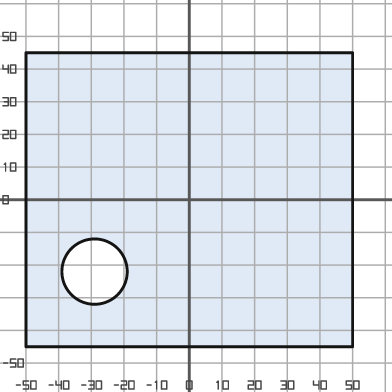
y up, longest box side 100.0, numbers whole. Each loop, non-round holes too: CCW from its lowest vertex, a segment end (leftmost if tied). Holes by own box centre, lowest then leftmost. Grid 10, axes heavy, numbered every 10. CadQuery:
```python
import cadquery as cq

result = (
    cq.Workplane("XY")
    .moveTo(-50.0, -45.0)
    .lineTo(50.0, -45.0)
    .lineTo(50.0, 45.0)
    .lineTo(-50.0, 45.0)
    .close()
    .moveTo(-29.0, -22.0)
    .circle(10.0)
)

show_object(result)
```